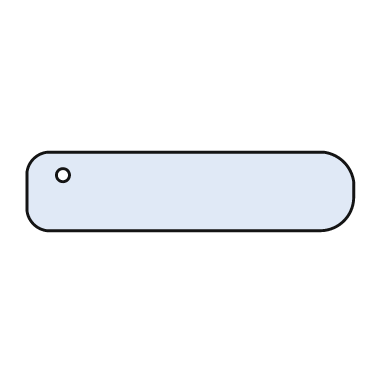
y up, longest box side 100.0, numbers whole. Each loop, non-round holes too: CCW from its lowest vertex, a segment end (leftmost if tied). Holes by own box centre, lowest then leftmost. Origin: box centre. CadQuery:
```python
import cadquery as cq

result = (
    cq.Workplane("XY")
    .moveTo(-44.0, -12.0)
    .lineTo(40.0, -12.0)
    .threePointArc((47.0, -9.0), (50.0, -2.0))
    .lineTo(50.0, 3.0)
    .threePointArc((47.0, 9.0), (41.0, 12.0))
    .lineTo(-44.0, 12.0)
    .threePointArc((-48.0, 10.0), (-50.0, 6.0))
    .lineTo(-50.0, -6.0)
    .threePointArc((-48.0, -10.0), (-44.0, -12.0))
    .close()
    .moveTo(-39.0, 5.0)
    .circle(2.0)
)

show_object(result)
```